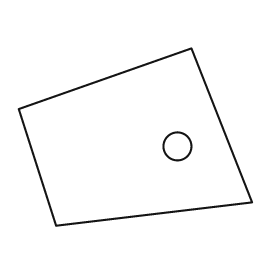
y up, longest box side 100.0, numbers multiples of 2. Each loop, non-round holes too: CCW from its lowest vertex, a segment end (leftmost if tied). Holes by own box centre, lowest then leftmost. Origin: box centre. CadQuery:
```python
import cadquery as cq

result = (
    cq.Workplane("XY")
    .moveTo(-34.0, -38.0)
    .lineTo(50.0, -28.0)
    .lineTo(24.0, 38.0)
    .lineTo(-50.0, 12.0)
    .close()
    .moveTo(18.0, -4.0)
    .circle(6.0)
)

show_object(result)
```